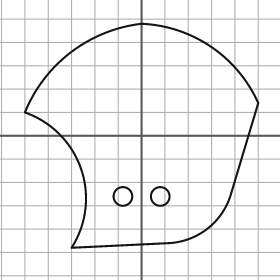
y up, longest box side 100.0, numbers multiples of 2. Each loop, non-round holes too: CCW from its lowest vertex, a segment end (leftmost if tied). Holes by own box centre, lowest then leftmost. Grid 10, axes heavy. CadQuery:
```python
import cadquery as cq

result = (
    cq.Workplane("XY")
    .moveTo(-30.0, -48.0)
    .lineTo(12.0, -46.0)
    .threePointArc((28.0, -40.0), (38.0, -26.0))
    .lineTo(50.0, 14.0)
    .threePointArc((30.0, 38.0), (0.0, 48.0))
    .threePointArc((-30.0, 36.0), (-50.0, 10.0))
    .threePointArc((-26.0, -14.0), (-30.0, -48.0))
    .close()
    .moveTo(-8.0, -26.0)
    .circle(4.0)
    .moveTo(8.0, -26.0)
    .circle(4.0)
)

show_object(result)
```